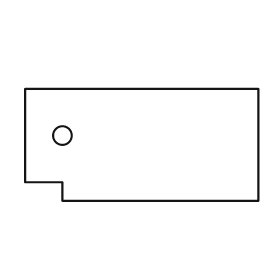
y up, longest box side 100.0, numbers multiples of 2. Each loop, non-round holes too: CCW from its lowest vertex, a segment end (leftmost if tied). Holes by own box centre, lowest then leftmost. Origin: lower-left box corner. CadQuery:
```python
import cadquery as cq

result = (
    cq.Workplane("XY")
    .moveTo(16.0, 0.0)
    .lineTo(100.0, 0.0)
    .lineTo(100.0, 48.0)
    .lineTo(0.0, 48.0)
    .lineTo(0.0, 8.0)
    .lineTo(16.0, 8.0)
    .close()
    .moveTo(16.0, 28.0)
    .circle(4.0)
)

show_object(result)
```